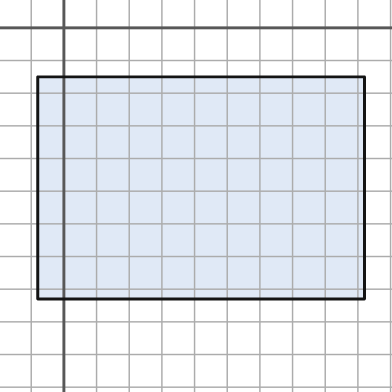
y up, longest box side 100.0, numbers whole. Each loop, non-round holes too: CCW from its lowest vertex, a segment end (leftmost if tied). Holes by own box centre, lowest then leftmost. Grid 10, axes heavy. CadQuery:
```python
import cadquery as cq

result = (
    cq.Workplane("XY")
    .moveTo(-8.0, -83.0)
    .lineTo(92.0, -83.0)
    .lineTo(92.0, -15.0)
    .lineTo(-8.0, -15.0)
    .close()
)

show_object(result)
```